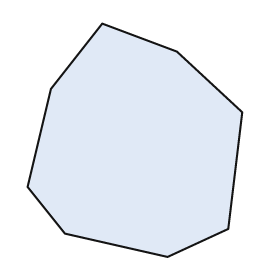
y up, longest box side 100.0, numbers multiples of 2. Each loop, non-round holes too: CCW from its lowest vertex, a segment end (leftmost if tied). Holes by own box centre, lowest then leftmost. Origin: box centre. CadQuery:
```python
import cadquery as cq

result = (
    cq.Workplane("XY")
    .moveTo(14.0, -50.0)
    .lineTo(40.0, -38.0)
    .lineTo(46.0, 12.0)
    .lineTo(18.0, 38.0)
    .lineTo(-14.0, 50.0)
    .lineTo(-36.0, 22.0)
    .lineTo(-46.0, -20.0)
    .lineTo(-30.0, -40.0)
    .close()
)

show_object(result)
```